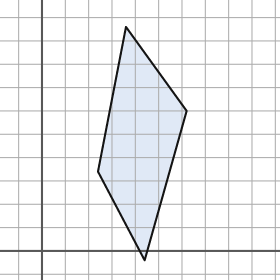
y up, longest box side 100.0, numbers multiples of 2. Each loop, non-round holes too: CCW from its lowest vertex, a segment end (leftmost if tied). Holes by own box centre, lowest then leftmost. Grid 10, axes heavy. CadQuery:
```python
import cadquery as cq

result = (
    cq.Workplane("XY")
    .moveTo(44.0, -4.0)
    .lineTo(62.0, 60.0)
    .lineTo(36.0, 96.0)
    .lineTo(24.0, 34.0)
    .close()
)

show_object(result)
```